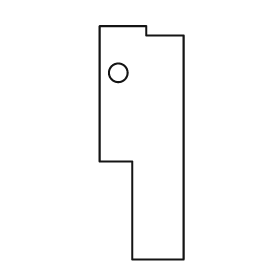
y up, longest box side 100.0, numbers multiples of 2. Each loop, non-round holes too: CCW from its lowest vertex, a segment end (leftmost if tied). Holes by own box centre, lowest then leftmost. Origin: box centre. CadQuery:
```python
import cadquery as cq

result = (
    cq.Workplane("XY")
    .moveTo(-4.0, -50.0)
    .lineTo(18.0, -50.0)
    .lineTo(18.0, 46.0)
    .lineTo(2.0, 46.0)
    .lineTo(2.0, 50.0)
    .lineTo(-18.0, 50.0)
    .lineTo(-18.0, -8.0)
    .lineTo(-4.0, -8.0)
    .close()
    .moveTo(-10.0, 30.0)
    .circle(4.0)
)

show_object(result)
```